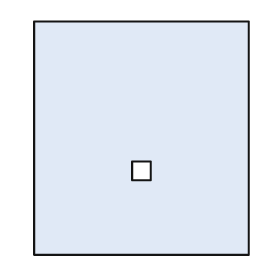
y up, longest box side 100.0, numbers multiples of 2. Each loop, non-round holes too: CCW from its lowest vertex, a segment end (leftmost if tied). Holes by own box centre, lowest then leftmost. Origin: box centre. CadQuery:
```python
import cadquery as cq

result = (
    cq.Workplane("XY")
    .moveTo(-46.0, -50.0)
    .lineTo(46.0, -50.0)
    .lineTo(46.0, 50.0)
    .lineTo(-46.0, 50.0)
    .close()
    .moveTo(-4.0, -18.0)
    .lineTo(4.0, -18.0)
    .lineTo(4.0, -10.0)
    .lineTo(-4.0, -10.0)
    .close()
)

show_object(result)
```